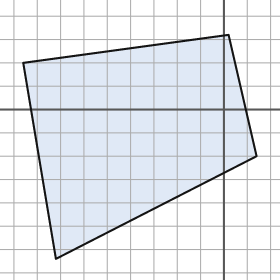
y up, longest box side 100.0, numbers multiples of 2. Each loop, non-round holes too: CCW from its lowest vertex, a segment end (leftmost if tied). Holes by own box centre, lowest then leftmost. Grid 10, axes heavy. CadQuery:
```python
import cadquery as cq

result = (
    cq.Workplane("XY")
    .moveTo(-72.0, -64.0)
    .lineTo(14.0, -20.0)
    .lineTo(2.0, 32.0)
    .lineTo(-86.0, 20.0)
    .close()
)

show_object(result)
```